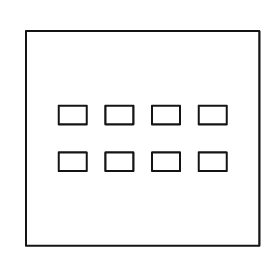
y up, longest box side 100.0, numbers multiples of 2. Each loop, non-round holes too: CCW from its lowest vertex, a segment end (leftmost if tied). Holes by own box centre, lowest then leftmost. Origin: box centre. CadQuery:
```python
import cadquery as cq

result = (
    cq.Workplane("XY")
    .moveTo(-50.0, -46.0)
    .lineTo(50.0, -46.0)
    .lineTo(50.0, 46.0)
    .lineTo(-50.0, 46.0)
    .close()
    .moveTo(-36.0, -14.0)
    .lineTo(-24.0, -14.0)
    .lineTo(-24.0, -6.0)
    .lineTo(-36.0, -6.0)
    .close()
    .moveTo(-16.0, -14.0)
    .lineTo(-4.0, -14.0)
    .lineTo(-4.0, -6.0)
    .lineTo(-16.0, -6.0)
    .close()
    .moveTo(4.0, -14.0)
    .lineTo(16.0, -14.0)
    .lineTo(16.0, -6.0)
    .lineTo(4.0, -6.0)
    .close()
    .moveTo(24.0, -14.0)
    .lineTo(36.0, -14.0)
    .lineTo(36.0, -6.0)
    .lineTo(24.0, -6.0)
    .close()
    .moveTo(-36.0, 6.0)
    .lineTo(-24.0, 6.0)
    .lineTo(-24.0, 14.0)
    .lineTo(-36.0, 14.0)
    .close()
    .moveTo(-16.0, 6.0)
    .lineTo(-4.0, 6.0)
    .lineTo(-4.0, 14.0)
    .lineTo(-16.0, 14.0)
    .close()
    .moveTo(4.0, 6.0)
    .lineTo(16.0, 6.0)
    .lineTo(16.0, 14.0)
    .lineTo(4.0, 14.0)
    .close()
    .moveTo(24.0, 6.0)
    .lineTo(36.0, 6.0)
    .lineTo(36.0, 14.0)
    .lineTo(24.0, 14.0)
    .close()
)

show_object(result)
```